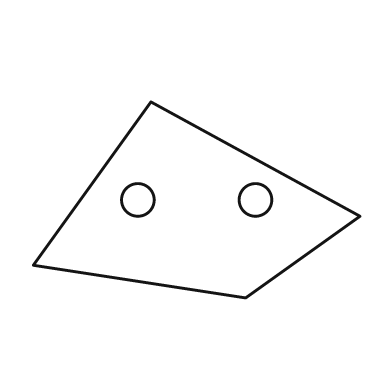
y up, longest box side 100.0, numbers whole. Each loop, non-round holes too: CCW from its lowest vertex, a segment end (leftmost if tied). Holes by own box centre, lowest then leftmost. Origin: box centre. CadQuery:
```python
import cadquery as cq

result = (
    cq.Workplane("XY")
    .moveTo(15.0, -30.0)
    .lineTo(50.0, -5.0)
    .lineTo(-14.0, 30.0)
    .lineTo(-50.0, -20.0)
    .close()
    .moveTo(-18.0, 0.0)
    .circle(5.0)
    .moveTo(18.0, 0.0)
    .circle(5.0)
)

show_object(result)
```